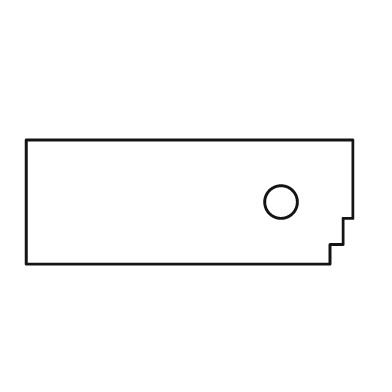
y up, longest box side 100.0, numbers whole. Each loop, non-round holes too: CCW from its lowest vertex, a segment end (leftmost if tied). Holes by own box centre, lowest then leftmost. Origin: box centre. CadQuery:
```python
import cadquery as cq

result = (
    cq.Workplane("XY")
    .moveTo(-50.0, -19.0)
    .lineTo(43.0, -19.0)
    .lineTo(43.0, -13.0)
    .lineTo(47.0, -13.0)
    .lineTo(47.0, -5.0)
    .lineTo(50.0, -5.0)
    .lineTo(50.0, 19.0)
    .lineTo(-50.0, 19.0)
    .close()
    .moveTo(28.0, 0.0)
    .circle(5.0)
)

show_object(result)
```